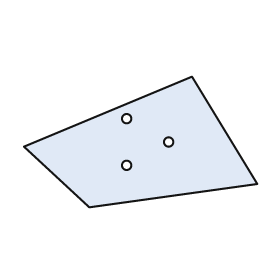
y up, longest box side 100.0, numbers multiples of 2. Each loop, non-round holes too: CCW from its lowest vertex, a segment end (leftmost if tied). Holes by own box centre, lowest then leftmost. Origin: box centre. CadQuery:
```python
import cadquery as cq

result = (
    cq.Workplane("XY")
    .moveTo(-22.0, -28.0)
    .lineTo(50.0, -18.0)
    .lineTo(22.0, 28.0)
    .lineTo(-50.0, -2.0)
    .close()
    .moveTo(-6.0, -10.0)
    .circle(2.0)
    .moveTo(12.0, 0.0)
    .circle(2.0)
    .moveTo(-6.0, 10.0)
    .circle(2.0)
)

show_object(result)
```